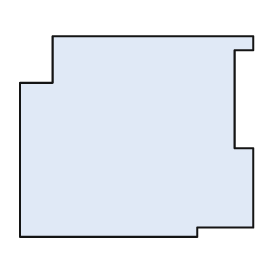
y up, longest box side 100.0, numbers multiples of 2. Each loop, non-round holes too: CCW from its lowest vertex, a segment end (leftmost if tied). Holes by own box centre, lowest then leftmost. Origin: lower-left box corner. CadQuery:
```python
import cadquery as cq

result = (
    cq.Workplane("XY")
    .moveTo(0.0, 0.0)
    .lineTo(76.0, 0.0)
    .lineTo(76.0, 4.0)
    .lineTo(100.0, 4.0)
    .lineTo(100.0, 38.0)
    .lineTo(92.0, 38.0)
    .lineTo(92.0, 80.0)
    .lineTo(100.0, 80.0)
    .lineTo(100.0, 86.0)
    .lineTo(14.0, 86.0)
    .lineTo(14.0, 66.0)
    .lineTo(0.0, 66.0)
    .close()
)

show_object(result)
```